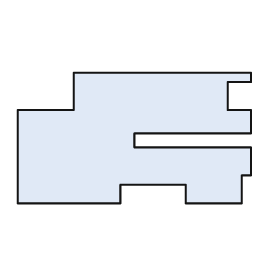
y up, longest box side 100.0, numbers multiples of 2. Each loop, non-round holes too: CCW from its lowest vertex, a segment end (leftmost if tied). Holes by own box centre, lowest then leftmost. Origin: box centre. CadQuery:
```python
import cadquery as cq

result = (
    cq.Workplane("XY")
    .moveTo(-50.0, -28.0)
    .lineTo(-6.0, -28.0)
    .lineTo(-6.0, -20.0)
    .lineTo(22.0, -20.0)
    .lineTo(22.0, -28.0)
    .lineTo(46.0, -28.0)
    .lineTo(46.0, -16.0)
    .lineTo(50.0, -16.0)
    .lineTo(50.0, -4.0)
    .lineTo(0.0, -4.0)
    .lineTo(0.0, 2.0)
    .lineTo(50.0, 2.0)
    .lineTo(50.0, 12.0)
    .lineTo(40.0, 12.0)
    .lineTo(40.0, 24.0)
    .lineTo(50.0, 24.0)
    .lineTo(50.0, 28.0)
    .lineTo(-26.0, 28.0)
    .lineTo(-26.0, 12.0)
    .lineTo(-50.0, 12.0)
    .close()
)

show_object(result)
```